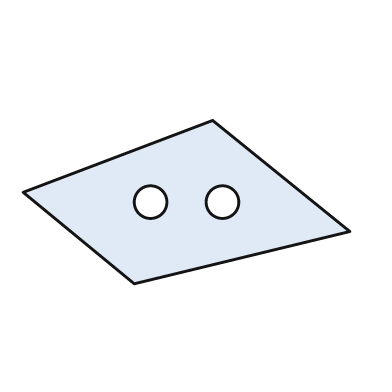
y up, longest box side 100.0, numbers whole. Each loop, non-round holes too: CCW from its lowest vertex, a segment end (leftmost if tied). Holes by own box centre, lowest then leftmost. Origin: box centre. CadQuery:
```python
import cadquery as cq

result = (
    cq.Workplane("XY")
    .moveTo(-16.0, -25.0)
    .lineTo(50.0, -9.0)
    .lineTo(8.0, 25.0)
    .lineTo(-50.0, 3.0)
    .close()
    .moveTo(-11.0, 0.0)
    .circle(5.0)
    .moveTo(11.0, 0.0)
    .circle(5.0)
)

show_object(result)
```